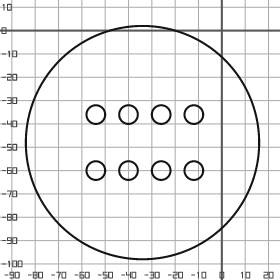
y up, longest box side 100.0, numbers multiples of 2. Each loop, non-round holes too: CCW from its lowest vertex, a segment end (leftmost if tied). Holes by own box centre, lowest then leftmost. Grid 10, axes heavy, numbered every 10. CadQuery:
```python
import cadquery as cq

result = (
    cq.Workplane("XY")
    .moveTo(-34.0, -48.0)
    .circle(50.0)
    .moveTo(-54.0, -60.0)
    .circle(4.0)
    .moveTo(-40.0, -60.0)
    .circle(4.0)
    .moveTo(-26.0, -60.0)
    .circle(4.0)
    .moveTo(-12.0, -60.0)
    .circle(4.0)
    .moveTo(-54.0, -36.0)
    .circle(4.0)
    .moveTo(-40.0, -36.0)
    .circle(4.0)
    .moveTo(-26.0, -36.0)
    .circle(4.0)
    .moveTo(-12.0, -36.0)
    .circle(4.0)
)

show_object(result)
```